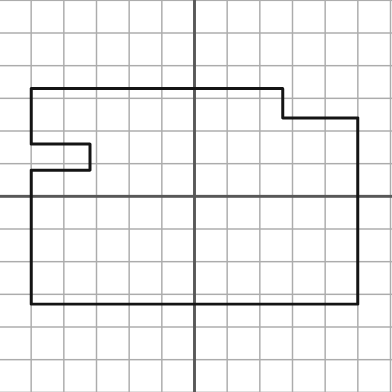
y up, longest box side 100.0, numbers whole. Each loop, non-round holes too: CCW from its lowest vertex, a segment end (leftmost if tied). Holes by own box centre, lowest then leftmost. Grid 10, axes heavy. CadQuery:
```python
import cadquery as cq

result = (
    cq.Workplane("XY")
    .moveTo(-50.0, -33.0)
    .lineTo(50.0, -33.0)
    .lineTo(50.0, 24.0)
    .lineTo(27.0, 24.0)
    .lineTo(27.0, 33.0)
    .lineTo(-50.0, 33.0)
    .lineTo(-50.0, 16.0)
    .lineTo(-32.0, 16.0)
    .lineTo(-32.0, 8.0)
    .lineTo(-50.0, 8.0)
    .close()
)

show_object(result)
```